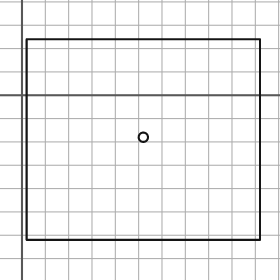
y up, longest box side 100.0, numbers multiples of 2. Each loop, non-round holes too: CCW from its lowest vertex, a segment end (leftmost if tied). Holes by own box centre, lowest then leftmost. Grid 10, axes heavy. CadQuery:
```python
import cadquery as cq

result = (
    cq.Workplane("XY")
    .moveTo(2.0, -62.0)
    .lineTo(102.0, -62.0)
    .lineTo(102.0, 24.0)
    .lineTo(2.0, 24.0)
    .close()
    .moveTo(52.0, -18.0)
    .circle(2.0)
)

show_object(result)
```